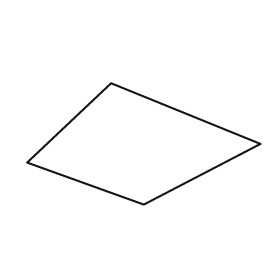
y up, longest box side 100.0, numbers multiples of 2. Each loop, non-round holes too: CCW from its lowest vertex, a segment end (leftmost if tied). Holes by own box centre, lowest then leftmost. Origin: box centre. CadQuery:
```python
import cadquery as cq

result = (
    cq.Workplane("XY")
    .moveTo(0.0, -26.0)
    .lineTo(50.0, 0.0)
    .lineTo(-14.0, 26.0)
    .lineTo(-50.0, -8.0)
    .close()
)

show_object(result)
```